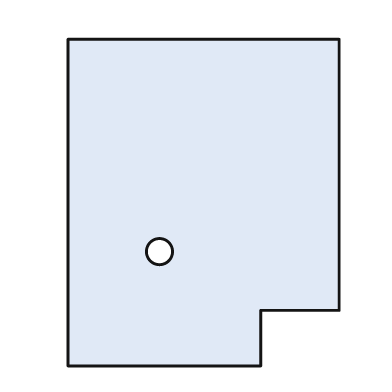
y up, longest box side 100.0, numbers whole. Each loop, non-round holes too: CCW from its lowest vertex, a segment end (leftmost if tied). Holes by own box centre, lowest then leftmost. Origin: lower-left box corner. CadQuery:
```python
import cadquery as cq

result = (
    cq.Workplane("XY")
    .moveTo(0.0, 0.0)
    .lineTo(59.0, 0.0)
    .lineTo(59.0, 17.0)
    .lineTo(83.0, 17.0)
    .lineTo(83.0, 100.0)
    .lineTo(0.0, 100.0)
    .close()
    .moveTo(28.0, 35.0)
    .circle(4.0)
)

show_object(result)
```